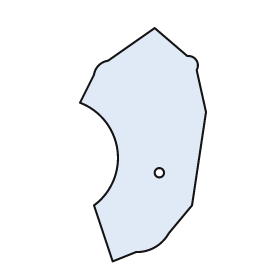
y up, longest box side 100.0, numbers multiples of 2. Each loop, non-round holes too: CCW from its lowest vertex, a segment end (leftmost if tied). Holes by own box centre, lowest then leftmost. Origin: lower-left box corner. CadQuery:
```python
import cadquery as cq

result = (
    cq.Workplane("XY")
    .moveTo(14.0, 0.0)
    .lineTo(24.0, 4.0)
    .threePointArc((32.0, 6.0), (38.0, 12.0))
    .lineTo(48.0, 24.0)
    .lineTo(54.0, 64.0)
    .lineTo(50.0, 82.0)
    .threePointArc((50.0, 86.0), (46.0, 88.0))
    .lineTo(32.0, 100.0)
    .lineTo(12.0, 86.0)
    .threePointArc((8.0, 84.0), (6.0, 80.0))
    .lineTo(0.0, 68.0)
    .threePointArc((16.0, 48.0), (6.0, 24.0))
    .close()
    .moveTo(34.0, 38.0)
    .circle(2.0)
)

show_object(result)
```